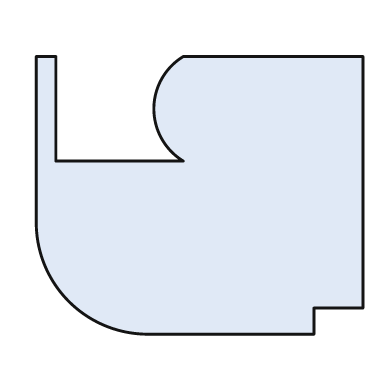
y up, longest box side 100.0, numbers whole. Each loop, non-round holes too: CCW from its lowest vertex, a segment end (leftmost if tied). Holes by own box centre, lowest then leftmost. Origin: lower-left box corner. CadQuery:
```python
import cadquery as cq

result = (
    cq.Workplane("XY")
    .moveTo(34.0, 0.0)
    .lineTo(85.0, 0.0)
    .lineTo(85.0, 8.0)
    .lineTo(100.0, 8.0)
    .lineTo(100.0, 85.0)
    .lineTo(45.0, 85.0)
    .threePointArc((36.0, 69.0), (45.0, 53.0))
    .lineTo(6.0, 53.0)
    .lineTo(6.0, 85.0)
    .lineTo(0.0, 85.0)
    .lineTo(0.0, 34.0)
    .threePointArc((10.0, 10.0), (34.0, 0.0))
    .close()
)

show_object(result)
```